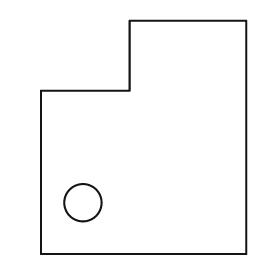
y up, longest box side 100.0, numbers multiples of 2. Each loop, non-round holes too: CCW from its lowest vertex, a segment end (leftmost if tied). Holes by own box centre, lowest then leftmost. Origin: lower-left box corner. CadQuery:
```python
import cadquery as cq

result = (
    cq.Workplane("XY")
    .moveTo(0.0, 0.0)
    .lineTo(88.0, 0.0)
    .lineTo(88.0, 100.0)
    .lineTo(38.0, 100.0)
    .lineTo(38.0, 70.0)
    .lineTo(0.0, 70.0)
    .close()
    .moveTo(18.0, 22.0)
    .circle(8.0)
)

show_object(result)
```